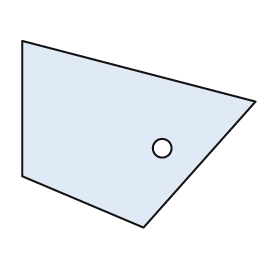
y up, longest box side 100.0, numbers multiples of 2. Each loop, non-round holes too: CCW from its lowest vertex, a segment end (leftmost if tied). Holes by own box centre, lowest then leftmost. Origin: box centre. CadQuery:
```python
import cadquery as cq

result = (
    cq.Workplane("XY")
    .moveTo(2.0, -40.0)
    .lineTo(50.0, 14.0)
    .lineTo(-50.0, 40.0)
    .lineTo(-50.0, -18.0)
    .close()
    .moveTo(10.0, -6.0)
    .circle(4.0)
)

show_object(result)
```